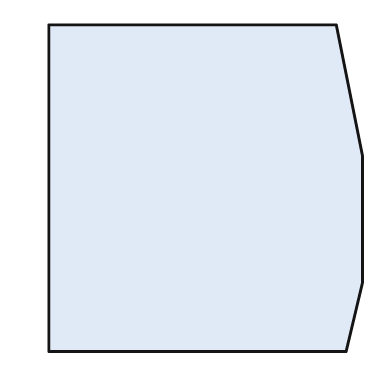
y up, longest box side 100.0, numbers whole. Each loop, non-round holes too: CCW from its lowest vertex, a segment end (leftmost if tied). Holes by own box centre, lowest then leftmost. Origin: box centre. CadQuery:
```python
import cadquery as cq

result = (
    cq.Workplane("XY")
    .moveTo(-48.0, -50.0)
    .lineTo(43.0, -50.0)
    .lineTo(48.0, -29.0)
    .lineTo(48.0, 10.0)
    .lineTo(40.0, 50.0)
    .lineTo(-48.0, 50.0)
    .close()
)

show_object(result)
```